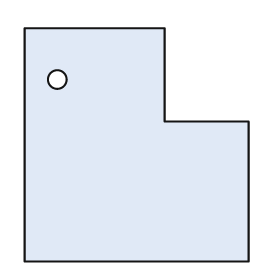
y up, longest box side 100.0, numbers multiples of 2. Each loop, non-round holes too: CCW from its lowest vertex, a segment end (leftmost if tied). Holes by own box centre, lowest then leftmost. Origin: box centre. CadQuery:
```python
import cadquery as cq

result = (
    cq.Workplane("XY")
    .moveTo(-48.0, -50.0)
    .lineTo(48.0, -50.0)
    .lineTo(48.0, 10.0)
    .lineTo(12.0, 10.0)
    .lineTo(12.0, 50.0)
    .lineTo(-48.0, 50.0)
    .close()
    .moveTo(-34.0, 28.0)
    .circle(4.0)
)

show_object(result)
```